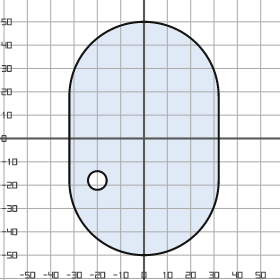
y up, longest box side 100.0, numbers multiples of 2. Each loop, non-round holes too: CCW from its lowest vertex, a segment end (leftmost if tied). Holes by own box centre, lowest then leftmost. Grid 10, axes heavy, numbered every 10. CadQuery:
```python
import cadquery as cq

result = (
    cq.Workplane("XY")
    .moveTo(-32.0, -18.0)
    .threePointArc((0.0, -50.0), (32.0, -18.0))
    .lineTo(32.0, 18.0)
    .threePointArc((0.0, 50.0), (-32.0, 18.0))
    .close()
    .moveTo(-20.0, -18.0)
    .circle(4.0)
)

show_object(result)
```